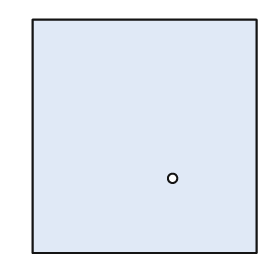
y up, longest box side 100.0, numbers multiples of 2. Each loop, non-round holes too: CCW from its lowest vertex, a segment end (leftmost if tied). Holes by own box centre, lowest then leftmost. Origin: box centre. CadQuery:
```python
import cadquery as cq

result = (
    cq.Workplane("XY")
    .moveTo(-48.0, -50.0)
    .lineTo(48.0, -50.0)
    .lineTo(48.0, 50.0)
    .lineTo(-48.0, 50.0)
    .close()
    .moveTo(12.0, -18.0)
    .circle(2.0)
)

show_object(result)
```